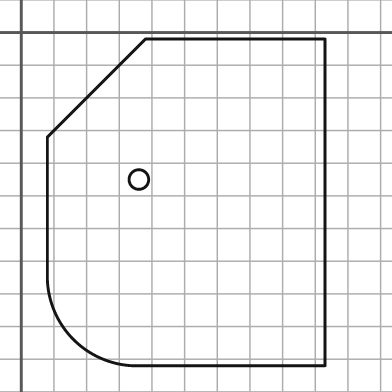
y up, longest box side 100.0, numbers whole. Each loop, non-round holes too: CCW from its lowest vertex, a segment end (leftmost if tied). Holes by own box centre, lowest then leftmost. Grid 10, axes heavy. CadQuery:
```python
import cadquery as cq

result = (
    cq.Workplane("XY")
    .moveTo(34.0, -102.0)
    .lineTo(93.0, -102.0)
    .lineTo(93.0, -2.0)
    .lineTo(38.0, -2.0)
    .lineTo(8.0, -32.0)
    .lineTo(8.0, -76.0)
    .threePointArc((16.0, -94.0), (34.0, -102.0))
    .close()
    .moveTo(36.0, -45.0)
    .circle(3.0)
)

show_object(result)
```